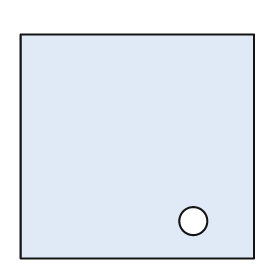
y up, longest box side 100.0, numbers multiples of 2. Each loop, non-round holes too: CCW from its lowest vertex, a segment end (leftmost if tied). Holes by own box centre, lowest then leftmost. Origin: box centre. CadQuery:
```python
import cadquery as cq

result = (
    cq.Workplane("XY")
    .moveTo(-50.0, -48.0)
    .lineTo(50.0, -48.0)
    .lineTo(50.0, 48.0)
    .lineTo(-50.0, 48.0)
    .close()
    .moveTo(24.0, -32.0)
    .circle(6.0)
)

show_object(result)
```